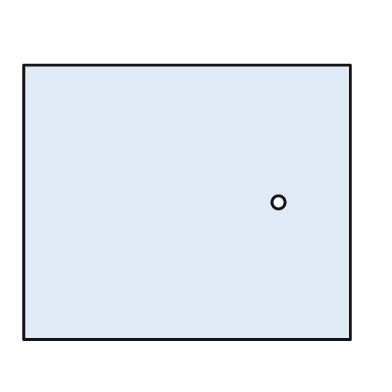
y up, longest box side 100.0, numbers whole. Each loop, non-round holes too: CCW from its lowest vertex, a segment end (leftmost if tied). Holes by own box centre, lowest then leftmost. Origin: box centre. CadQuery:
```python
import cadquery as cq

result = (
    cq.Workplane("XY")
    .moveTo(-50.0, -42.0)
    .lineTo(50.0, -42.0)
    .lineTo(50.0, 42.0)
    .lineTo(-50.0, 42.0)
    .close()
    .moveTo(28.0, 0.0)
    .circle(2.0)
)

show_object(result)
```